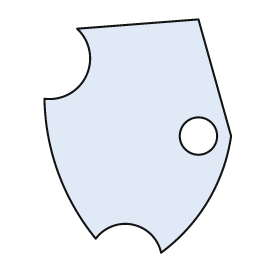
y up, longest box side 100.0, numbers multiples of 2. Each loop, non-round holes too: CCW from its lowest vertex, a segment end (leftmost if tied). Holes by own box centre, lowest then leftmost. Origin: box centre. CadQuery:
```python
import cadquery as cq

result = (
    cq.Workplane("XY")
    .moveTo(10.0, -50.0)
    .threePointArc((30.0, -28.0), (40.0, 0.0))
    .lineTo(26.0, 50.0)
    .lineTo(-26.0, 46.0)
    .threePointArc((-22.0, 26.0), (-40.0, 16.0))
    .threePointArc((-34.0, -16.0), (-18.0, -44.0))
    .threePointArc((-2.0, -38.0), (10.0, -50.0))
    .close()
    .moveTo(26.0, 0.0)
    .circle(8.0)
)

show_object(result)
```